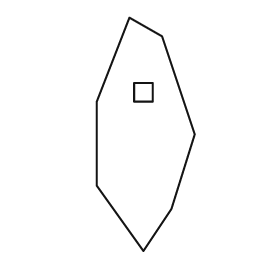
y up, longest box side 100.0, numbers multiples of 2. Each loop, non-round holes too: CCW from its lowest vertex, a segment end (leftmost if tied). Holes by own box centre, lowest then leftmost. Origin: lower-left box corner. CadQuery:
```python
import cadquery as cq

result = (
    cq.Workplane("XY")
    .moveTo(20.0, 0.0)
    .lineTo(32.0, 18.0)
    .lineTo(42.0, 50.0)
    .lineTo(28.0, 92.0)
    .lineTo(14.0, 100.0)
    .lineTo(0.0, 64.0)
    .lineTo(0.0, 28.0)
    .close()
    .moveTo(16.0, 64.0)
    .lineTo(24.0, 64.0)
    .lineTo(24.0, 72.0)
    .lineTo(16.0, 72.0)
    .close()
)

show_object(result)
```